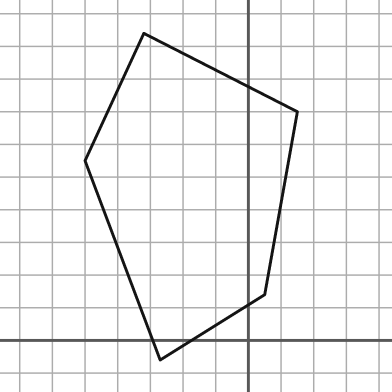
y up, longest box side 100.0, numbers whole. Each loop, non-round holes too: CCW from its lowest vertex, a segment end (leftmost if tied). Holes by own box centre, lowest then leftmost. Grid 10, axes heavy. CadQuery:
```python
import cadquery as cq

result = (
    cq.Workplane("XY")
    .moveTo(-27.0, -6.0)
    .lineTo(5.0, 14.0)
    .lineTo(15.0, 70.0)
    .lineTo(-32.0, 94.0)
    .lineTo(-50.0, 55.0)
    .close()
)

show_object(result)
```